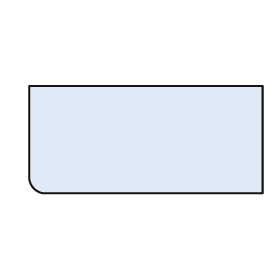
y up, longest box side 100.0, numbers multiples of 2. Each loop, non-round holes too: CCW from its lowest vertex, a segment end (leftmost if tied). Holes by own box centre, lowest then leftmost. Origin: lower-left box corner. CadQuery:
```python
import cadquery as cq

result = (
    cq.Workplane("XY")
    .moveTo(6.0, 0.0)
    .lineTo(100.0, 0.0)
    .lineTo(100.0, 46.0)
    .lineTo(0.0, 46.0)
    .lineTo(0.0, 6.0)
    .threePointArc((2.0, 2.0), (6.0, 0.0))
    .close()
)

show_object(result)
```